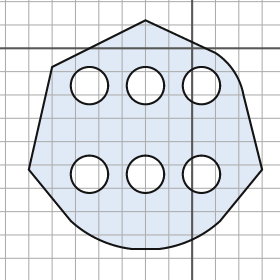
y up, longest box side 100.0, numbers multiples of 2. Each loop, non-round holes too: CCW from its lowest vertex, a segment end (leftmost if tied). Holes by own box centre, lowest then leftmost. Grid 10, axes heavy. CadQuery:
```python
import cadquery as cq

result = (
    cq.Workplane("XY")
    .moveTo(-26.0, -86.0)
    .lineTo(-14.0, -86.0)
    .threePointArc((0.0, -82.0), (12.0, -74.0))
    .lineTo(30.0, -52.0)
    .lineTo(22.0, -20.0)
    .threePointArc((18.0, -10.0), (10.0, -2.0))
    .lineTo(-20.0, 12.0)
    .lineTo(-60.0, -8.0)
    .lineTo(-70.0, -52.0)
    .lineTo(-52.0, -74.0)
    .threePointArc((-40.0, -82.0), (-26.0, -86.0))
    .close()
    .moveTo(-44.0, -54.0)
    .circle(8.0)
    .moveTo(-20.0, -54.0)
    .circle(8.0)
    .moveTo(4.0, -54.0)
    .circle(8.0)
    .moveTo(-44.0, -16.0)
    .circle(8.0)
    .moveTo(-20.0, -16.0)
    .circle(8.0)
    .moveTo(4.0, -16.0)
    .circle(8.0)
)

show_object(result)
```